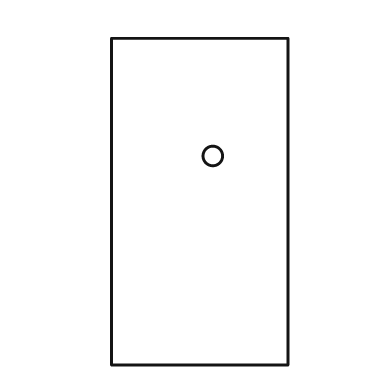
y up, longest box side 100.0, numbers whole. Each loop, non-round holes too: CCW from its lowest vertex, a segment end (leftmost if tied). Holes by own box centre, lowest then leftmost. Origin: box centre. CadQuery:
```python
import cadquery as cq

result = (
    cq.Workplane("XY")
    .moveTo(-27.0, -50.0)
    .lineTo(27.0, -50.0)
    .lineTo(27.0, 50.0)
    .lineTo(-27.0, 50.0)
    .close()
    .moveTo(4.0, 14.0)
    .circle(3.0)
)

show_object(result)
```